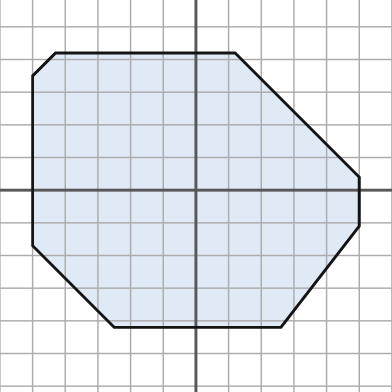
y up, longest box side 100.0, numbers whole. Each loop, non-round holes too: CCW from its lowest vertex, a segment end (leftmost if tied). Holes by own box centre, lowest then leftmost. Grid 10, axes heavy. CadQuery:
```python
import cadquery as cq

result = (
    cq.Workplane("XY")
    .moveTo(-25.0, -42.0)
    .lineTo(26.0, -42.0)
    .lineTo(50.0, -11.0)
    .lineTo(50.0, 4.0)
    .lineTo(12.0, 42.0)
    .lineTo(-43.0, 42.0)
    .lineTo(-50.0, 35.0)
    .lineTo(-50.0, -17.0)
    .close()
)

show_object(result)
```